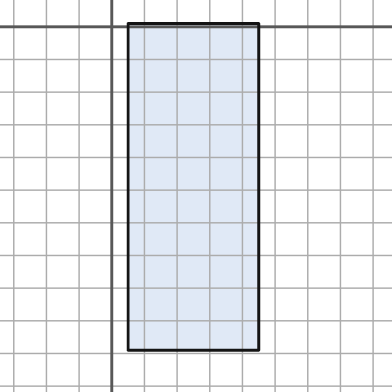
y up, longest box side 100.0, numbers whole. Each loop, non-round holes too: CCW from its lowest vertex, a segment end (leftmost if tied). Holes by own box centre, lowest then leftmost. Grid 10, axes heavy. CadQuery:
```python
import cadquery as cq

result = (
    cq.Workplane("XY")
    .moveTo(5.0, -99.0)
    .lineTo(45.0, -99.0)
    .lineTo(45.0, 1.0)
    .lineTo(5.0, 1.0)
    .close()
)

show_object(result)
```